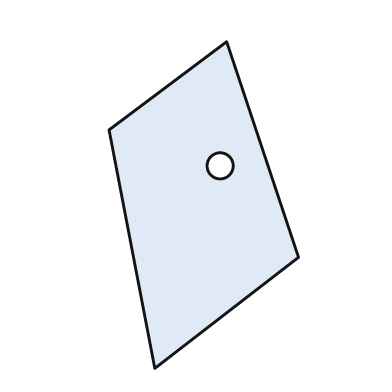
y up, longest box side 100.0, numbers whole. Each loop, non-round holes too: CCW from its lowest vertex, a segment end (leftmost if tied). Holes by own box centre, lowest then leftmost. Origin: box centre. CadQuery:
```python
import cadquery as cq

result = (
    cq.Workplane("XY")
    .moveTo(-15.0, -50.0)
    .lineTo(29.0, -16.0)
    .lineTo(7.0, 50.0)
    .lineTo(-29.0, 23.0)
    .close()
    .moveTo(5.0, 12.0)
    .circle(4.0)
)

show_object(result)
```